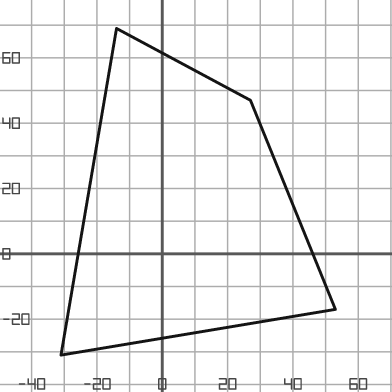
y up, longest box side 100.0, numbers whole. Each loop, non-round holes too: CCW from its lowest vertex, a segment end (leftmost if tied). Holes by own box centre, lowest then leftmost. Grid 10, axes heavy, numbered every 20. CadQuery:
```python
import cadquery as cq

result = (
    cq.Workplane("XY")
    .moveTo(-31.0, -31.0)
    .lineTo(53.0, -17.0)
    .lineTo(27.0, 47.0)
    .lineTo(-14.0, 69.0)
    .close()
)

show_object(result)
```